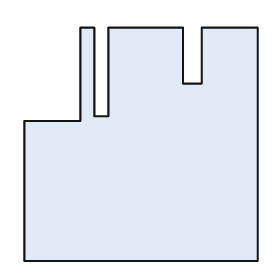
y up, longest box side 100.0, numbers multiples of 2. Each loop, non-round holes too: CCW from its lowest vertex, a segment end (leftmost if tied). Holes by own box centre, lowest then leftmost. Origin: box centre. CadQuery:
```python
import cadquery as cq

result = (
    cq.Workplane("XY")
    .moveTo(-50.0, -50.0)
    .lineTo(50.0, -50.0)
    .lineTo(50.0, 50.0)
    .lineTo(26.0, 50.0)
    .lineTo(26.0, 26.0)
    .lineTo(18.0, 26.0)
    .lineTo(18.0, 50.0)
    .lineTo(-14.0, 50.0)
    .lineTo(-14.0, 12.0)
    .lineTo(-20.0, 12.0)
    .lineTo(-20.0, 50.0)
    .lineTo(-26.0, 50.0)
    .lineTo(-26.0, 10.0)
    .lineTo(-50.0, 10.0)
    .close()
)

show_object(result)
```